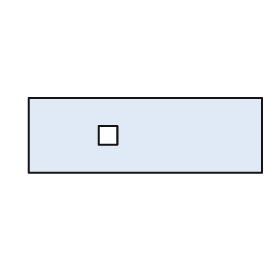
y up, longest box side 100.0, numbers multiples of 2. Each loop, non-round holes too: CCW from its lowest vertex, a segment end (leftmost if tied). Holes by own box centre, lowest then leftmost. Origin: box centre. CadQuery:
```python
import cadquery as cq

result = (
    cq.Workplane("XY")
    .moveTo(-50.0, -16.0)
    .lineTo(50.0, -16.0)
    .lineTo(50.0, 16.0)
    .lineTo(-50.0, 16.0)
    .close()
    .moveTo(-20.0, -4.0)
    .lineTo(-12.0, -4.0)
    .lineTo(-12.0, 4.0)
    .lineTo(-20.0, 4.0)
    .close()
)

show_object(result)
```